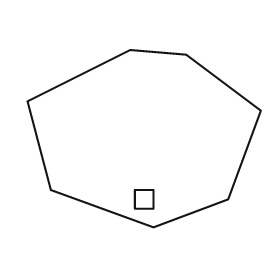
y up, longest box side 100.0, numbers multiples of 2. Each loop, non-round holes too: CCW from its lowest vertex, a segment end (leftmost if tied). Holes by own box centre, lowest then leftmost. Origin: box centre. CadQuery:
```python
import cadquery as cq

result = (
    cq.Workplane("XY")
    .moveTo(4.0, -38.0)
    .lineTo(36.0, -26.0)
    .lineTo(50.0, 12.0)
    .lineTo(18.0, 36.0)
    .lineTo(-6.0, 38.0)
    .lineTo(-50.0, 16.0)
    .lineTo(-40.0, -22.0)
    .close()
    .moveTo(-4.0, -30.0)
    .lineTo(4.0, -30.0)
    .lineTo(4.0, -22.0)
    .lineTo(-4.0, -22.0)
    .close()
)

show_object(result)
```